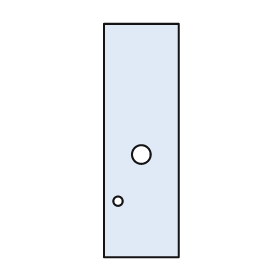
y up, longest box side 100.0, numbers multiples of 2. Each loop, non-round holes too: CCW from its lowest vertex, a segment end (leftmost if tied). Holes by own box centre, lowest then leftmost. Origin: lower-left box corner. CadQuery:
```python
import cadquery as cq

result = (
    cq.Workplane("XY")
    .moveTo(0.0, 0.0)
    .lineTo(32.0, 0.0)
    .lineTo(32.0, 100.0)
    .lineTo(0.0, 100.0)
    .close()
    .moveTo(6.0, 24.0)
    .circle(2.0)
    .moveTo(16.0, 44.0)
    .circle(4.0)
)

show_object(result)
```